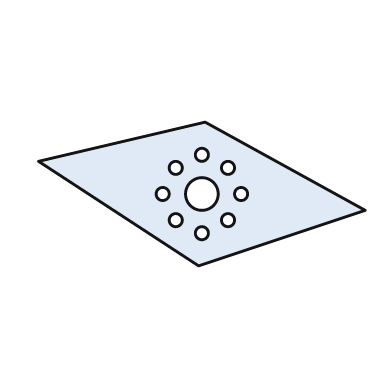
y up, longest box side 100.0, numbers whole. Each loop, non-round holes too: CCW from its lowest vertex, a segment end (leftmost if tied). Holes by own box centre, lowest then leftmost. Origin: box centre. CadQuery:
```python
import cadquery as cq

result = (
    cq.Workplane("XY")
    .moveTo(-1.0, -22.0)
    .lineTo(50.0, -5.0)
    .lineTo(1.0, 22.0)
    .lineTo(-50.0, 10.0)
    .close()
    .moveTo(0.0, -12.0)
    .circle(2.0)
    .moveTo(-8.0, -8.0)
    .circle(2.0)
    .moveTo(8.0, -8.0)
    .circle(2.0)
    .moveTo(-12.0, 0.0)
    .circle(2.0)
    .moveTo(0.0, 0.0)
    .circle(5.0)
    .moveTo(12.0, 0.0)
    .circle(2.0)
    .moveTo(-8.0, 8.0)
    .circle(2.0)
    .moveTo(8.0, 8.0)
    .circle(2.0)
    .moveTo(0.0, 12.0)
    .circle(2.0)
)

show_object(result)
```